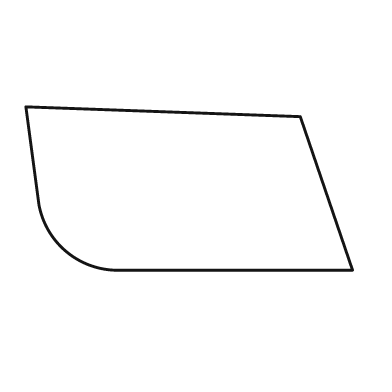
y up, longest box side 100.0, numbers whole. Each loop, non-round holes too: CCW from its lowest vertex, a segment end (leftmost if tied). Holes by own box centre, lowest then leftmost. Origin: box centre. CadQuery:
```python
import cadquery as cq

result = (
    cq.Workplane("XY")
    .moveTo(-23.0, -25.0)
    .lineTo(50.0, -25.0)
    .lineTo(34.0, 22.0)
    .lineTo(-50.0, 25.0)
    .lineTo(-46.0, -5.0)
    .threePointArc((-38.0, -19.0), (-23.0, -25.0))
    .close()
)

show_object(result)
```